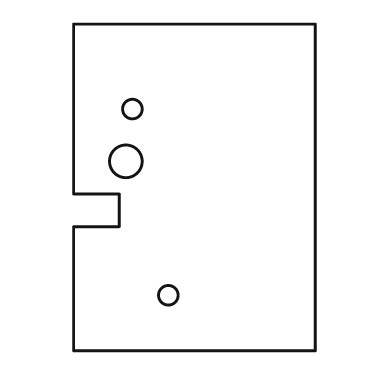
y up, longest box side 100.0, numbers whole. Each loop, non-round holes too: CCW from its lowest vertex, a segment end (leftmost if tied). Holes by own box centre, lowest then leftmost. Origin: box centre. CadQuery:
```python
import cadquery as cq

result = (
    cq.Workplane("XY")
    .moveTo(-37.0, -50.0)
    .lineTo(37.0, -50.0)
    .lineTo(37.0, 50.0)
    .lineTo(-37.0, 50.0)
    .lineTo(-37.0, -2.0)
    .lineTo(-23.0, -2.0)
    .lineTo(-23.0, -12.0)
    .lineTo(-37.0, -12.0)
    .close()
    .moveTo(-8.0, -33.0)
    .circle(3.0)
    .moveTo(-21.0, 8.0)
    .circle(5.0)
    .moveTo(-19.0, 24.0)
    .circle(3.0)
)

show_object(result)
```